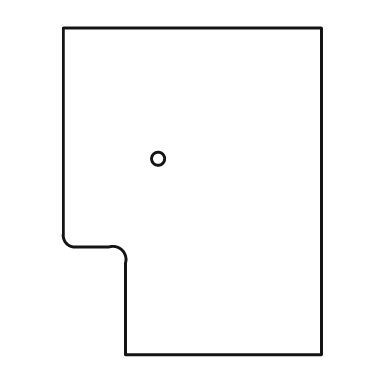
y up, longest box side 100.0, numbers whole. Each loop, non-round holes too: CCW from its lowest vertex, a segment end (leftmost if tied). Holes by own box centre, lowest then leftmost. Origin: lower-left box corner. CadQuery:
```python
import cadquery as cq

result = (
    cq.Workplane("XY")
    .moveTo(19.0, 0.0)
    .lineTo(79.0, 0.0)
    .lineTo(79.0, 100.0)
    .lineTo(0.0, 100.0)
    .lineTo(0.0, 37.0)
    .threePointArc((1.0, 34.0), (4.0, 33.0))
    .lineTo(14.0, 33.0)
    .threePointArc((18.0, 32.0), (19.0, 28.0))
    .close()
    .moveTo(29.0, 60.0)
    .circle(2.0)
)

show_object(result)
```